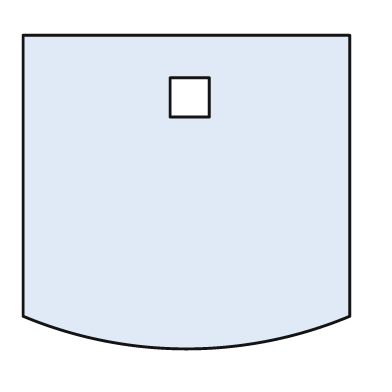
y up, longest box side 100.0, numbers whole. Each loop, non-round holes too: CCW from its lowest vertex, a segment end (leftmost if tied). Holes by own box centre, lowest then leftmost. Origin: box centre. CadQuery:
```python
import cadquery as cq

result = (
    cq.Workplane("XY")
    .moveTo(-50.0, -38.0)
    .threePointArc((0.0, -48.0), (50.0, -38.0))
    .lineTo(50.0, 48.0)
    .lineTo(-50.0, 48.0)
    .close()
    .moveTo(-5.0, 23.0)
    .lineTo(7.0, 23.0)
    .lineTo(7.0, 35.0)
    .lineTo(-5.0, 35.0)
    .close()
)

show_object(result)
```